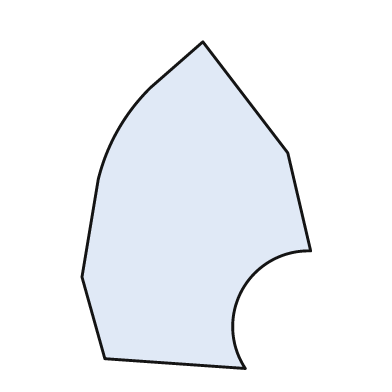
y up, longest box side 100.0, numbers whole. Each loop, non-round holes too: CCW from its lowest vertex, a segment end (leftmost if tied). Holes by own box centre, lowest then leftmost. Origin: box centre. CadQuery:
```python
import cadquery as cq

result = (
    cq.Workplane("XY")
    .moveTo(15.0, -50.0)
    .threePointArc((14.0, -26.0), (35.0, -14.0))
    .lineTo(28.0, 16.0)
    .lineTo(2.0, 50.0)
    .lineTo(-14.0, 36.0)
    .threePointArc((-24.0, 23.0), (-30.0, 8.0))
    .lineTo(-35.0, -22.0)
    .lineTo(-28.0, -47.0)
    .close()
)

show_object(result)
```